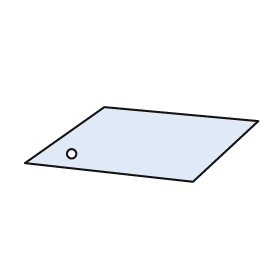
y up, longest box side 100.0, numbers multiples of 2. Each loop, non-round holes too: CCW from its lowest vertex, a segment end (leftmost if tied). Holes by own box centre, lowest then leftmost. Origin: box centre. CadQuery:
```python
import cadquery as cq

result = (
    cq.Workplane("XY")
    .moveTo(22.0, -16.0)
    .lineTo(50.0, 10.0)
    .lineTo(-16.0, 16.0)
    .lineTo(-50.0, -8.0)
    .close()
    .moveTo(-30.0, -4.0)
    .circle(2.0)
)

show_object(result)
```